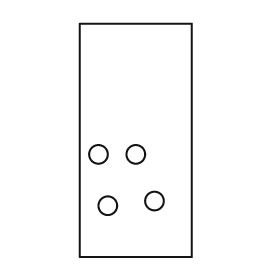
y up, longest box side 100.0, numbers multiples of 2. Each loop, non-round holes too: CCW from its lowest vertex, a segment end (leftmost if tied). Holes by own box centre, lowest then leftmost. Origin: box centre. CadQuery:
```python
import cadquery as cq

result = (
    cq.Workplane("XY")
    .moveTo(-24.0, -50.0)
    .lineTo(24.0, -50.0)
    .lineTo(24.0, 50.0)
    .lineTo(-24.0, 50.0)
    .close()
    .moveTo(-12.0, -28.0)
    .circle(4.0)
    .moveTo(8.0, -26.0)
    .circle(4.0)
    .moveTo(-16.0, -6.0)
    .circle(4.0)
    .moveTo(0.0, -6.0)
    .circle(4.0)
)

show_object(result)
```